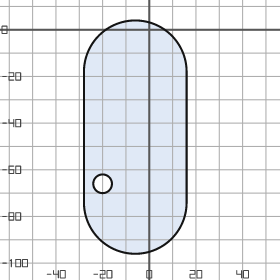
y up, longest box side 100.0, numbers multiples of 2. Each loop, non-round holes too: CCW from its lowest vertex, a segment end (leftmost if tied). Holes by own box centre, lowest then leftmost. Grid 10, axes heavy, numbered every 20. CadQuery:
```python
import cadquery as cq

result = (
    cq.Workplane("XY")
    .moveTo(-28.0, -74.0)
    .threePointArc((-6.0, -96.0), (16.0, -74.0))
    .lineTo(16.0, -18.0)
    .threePointArc((-6.0, 4.0), (-28.0, -18.0))
    .close()
    .moveTo(-20.0, -66.0)
    .circle(4.0)
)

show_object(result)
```